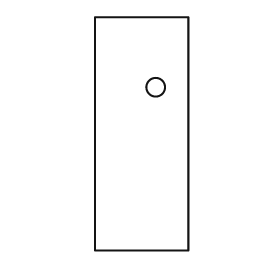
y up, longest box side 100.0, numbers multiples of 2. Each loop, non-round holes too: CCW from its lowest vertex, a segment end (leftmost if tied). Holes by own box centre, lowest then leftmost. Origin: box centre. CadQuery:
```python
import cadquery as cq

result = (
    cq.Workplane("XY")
    .moveTo(-20.0, -50.0)
    .lineTo(20.0, -50.0)
    .lineTo(20.0, 50.0)
    .lineTo(-20.0, 50.0)
    .close()
    .moveTo(6.0, 20.0)
    .circle(4.0)
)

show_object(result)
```